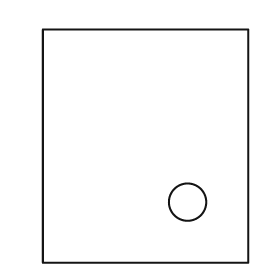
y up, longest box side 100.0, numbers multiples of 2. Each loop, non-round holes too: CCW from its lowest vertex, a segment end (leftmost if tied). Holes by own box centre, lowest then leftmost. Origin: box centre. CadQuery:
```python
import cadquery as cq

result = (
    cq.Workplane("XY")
    .moveTo(-44.0, -50.0)
    .lineTo(44.0, -50.0)
    .lineTo(44.0, 50.0)
    .lineTo(-44.0, 50.0)
    .close()
    .moveTo(18.0, -24.0)
    .circle(8.0)
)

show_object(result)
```